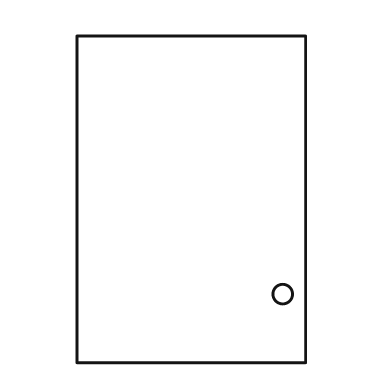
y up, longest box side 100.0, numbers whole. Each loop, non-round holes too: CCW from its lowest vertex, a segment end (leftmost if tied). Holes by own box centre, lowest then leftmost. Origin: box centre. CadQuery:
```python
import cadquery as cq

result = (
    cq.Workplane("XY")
    .moveTo(-35.0, -50.0)
    .lineTo(35.0, -50.0)
    .lineTo(35.0, 50.0)
    .lineTo(-35.0, 50.0)
    .close()
    .moveTo(28.0, -29.0)
    .circle(3.0)
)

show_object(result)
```